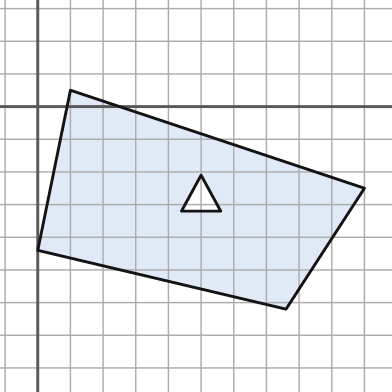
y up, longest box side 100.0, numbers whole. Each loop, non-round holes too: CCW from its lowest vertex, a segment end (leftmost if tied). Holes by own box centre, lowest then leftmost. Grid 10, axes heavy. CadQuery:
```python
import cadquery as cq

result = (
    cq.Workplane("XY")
    .moveTo(76.0, -62.0)
    .lineTo(100.0, -25.0)
    .lineTo(10.0, 5.0)
    .lineTo(0.0, -44.0)
    .close()
    .moveTo(44.0, -32.0)
    .lineTo(56.0, -32.0)
    .lineTo(50.0, -21.0)
    .close()
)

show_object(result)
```